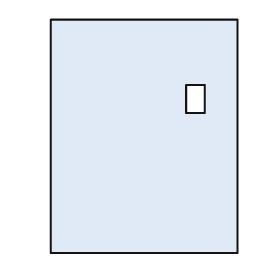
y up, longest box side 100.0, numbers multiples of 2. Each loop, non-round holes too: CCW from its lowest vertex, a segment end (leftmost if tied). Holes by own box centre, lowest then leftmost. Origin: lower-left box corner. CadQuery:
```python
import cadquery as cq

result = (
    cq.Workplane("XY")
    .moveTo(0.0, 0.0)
    .lineTo(80.0, 0.0)
    .lineTo(80.0, 100.0)
    .lineTo(0.0, 100.0)
    .close()
    .moveTo(58.0, 60.0)
    .lineTo(66.0, 60.0)
    .lineTo(66.0, 72.0)
    .lineTo(58.0, 72.0)
    .close()
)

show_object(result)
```